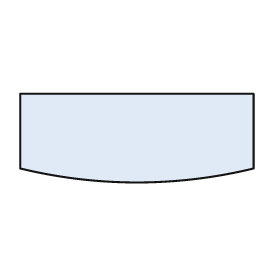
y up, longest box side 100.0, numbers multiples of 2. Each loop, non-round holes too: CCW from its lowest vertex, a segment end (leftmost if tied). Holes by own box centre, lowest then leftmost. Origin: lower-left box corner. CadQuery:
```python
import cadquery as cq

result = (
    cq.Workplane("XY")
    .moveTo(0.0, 6.0)
    .threePointArc((50.0, 0.0), (100.0, 6.0))
    .lineTo(100.0, 38.0)
    .lineTo(0.0, 38.0)
    .close()
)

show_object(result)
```